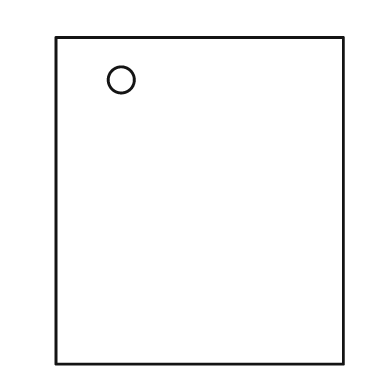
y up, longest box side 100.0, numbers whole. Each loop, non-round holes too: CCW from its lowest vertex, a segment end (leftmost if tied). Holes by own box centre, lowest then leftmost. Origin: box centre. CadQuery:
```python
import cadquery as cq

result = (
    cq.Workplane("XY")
    .moveTo(-44.0, -50.0)
    .lineTo(44.0, -50.0)
    .lineTo(44.0, 50.0)
    .lineTo(-44.0, 50.0)
    .close()
    .moveTo(-24.0, 37.0)
    .circle(4.0)
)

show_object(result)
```